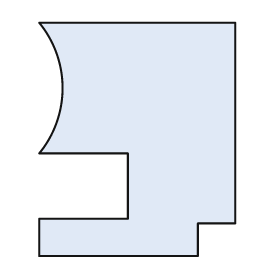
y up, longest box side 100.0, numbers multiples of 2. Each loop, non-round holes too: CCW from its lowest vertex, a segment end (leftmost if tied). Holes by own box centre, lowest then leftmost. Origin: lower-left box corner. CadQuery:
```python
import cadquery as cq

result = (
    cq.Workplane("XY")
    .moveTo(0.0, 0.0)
    .lineTo(68.0, 0.0)
    .lineTo(68.0, 14.0)
    .lineTo(84.0, 14.0)
    .lineTo(84.0, 100.0)
    .lineTo(0.0, 100.0)
    .threePointArc((10.0, 72.0), (0.0, 44.0))
    .lineTo(38.0, 44.0)
    .lineTo(38.0, 16.0)
    .lineTo(0.0, 16.0)
    .close()
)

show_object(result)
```